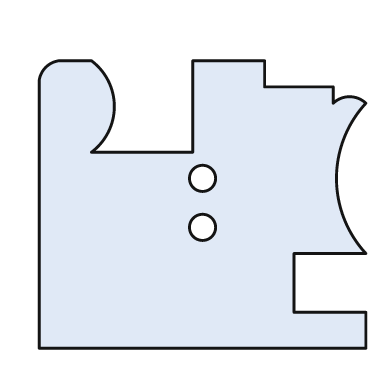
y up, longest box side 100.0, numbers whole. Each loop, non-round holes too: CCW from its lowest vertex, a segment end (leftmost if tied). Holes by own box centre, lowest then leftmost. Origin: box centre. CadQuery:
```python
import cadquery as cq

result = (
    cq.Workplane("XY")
    .moveTo(-50.0, -44.0)
    .lineTo(50.0, -44.0)
    .lineTo(50.0, -33.0)
    .lineTo(28.0, -33.0)
    .lineTo(28.0, -15.0)
    .lineTo(50.0, -15.0)
    .threePointArc((41.0, 8.0), (50.0, 31.0))
    .threePointArc((45.0, 33.0), (40.0, 31.0))
    .lineTo(40.0, 36.0)
    .lineTo(19.0, 36.0)
    .lineTo(19.0, 44.0)
    .lineTo(-3.0, 44.0)
    .lineTo(-3.0, 16.0)
    .lineTo(-34.0, 16.0)
    .threePointArc((-27.0, 30.0), (-34.0, 44.0))
    .lineTo(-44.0, 44.0)
    .threePointArc((-48.0, 42.0), (-50.0, 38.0))
    .close()
    .moveTo(0.0, -7.0)
    .circle(4.0)
    .moveTo(0.0, 8.0)
    .circle(4.0)
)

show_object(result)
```